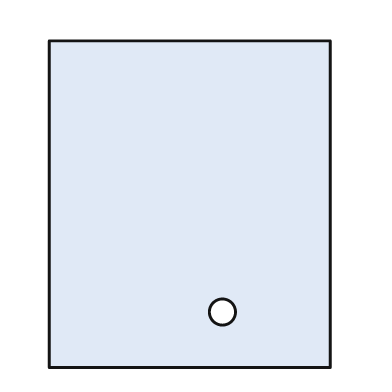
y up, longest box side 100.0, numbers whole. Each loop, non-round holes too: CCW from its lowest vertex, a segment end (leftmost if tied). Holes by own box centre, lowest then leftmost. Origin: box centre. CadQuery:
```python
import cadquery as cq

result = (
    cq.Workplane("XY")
    .moveTo(-43.0, -50.0)
    .lineTo(43.0, -50.0)
    .lineTo(43.0, 50.0)
    .lineTo(-43.0, 50.0)
    .close()
    .moveTo(10.0, -33.0)
    .circle(4.0)
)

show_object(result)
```